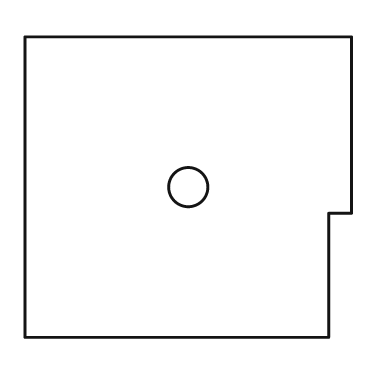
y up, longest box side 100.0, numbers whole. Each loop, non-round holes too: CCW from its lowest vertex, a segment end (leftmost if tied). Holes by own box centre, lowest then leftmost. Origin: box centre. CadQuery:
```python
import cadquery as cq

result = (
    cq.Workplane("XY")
    .moveTo(-50.0, -46.0)
    .lineTo(43.0, -46.0)
    .lineTo(43.0, -8.0)
    .lineTo(50.0, -8.0)
    .lineTo(50.0, 46.0)
    .lineTo(-50.0, 46.0)
    .close()
    .moveTo(0.0, 0.0)
    .circle(6.0)
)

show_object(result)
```